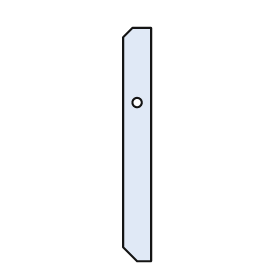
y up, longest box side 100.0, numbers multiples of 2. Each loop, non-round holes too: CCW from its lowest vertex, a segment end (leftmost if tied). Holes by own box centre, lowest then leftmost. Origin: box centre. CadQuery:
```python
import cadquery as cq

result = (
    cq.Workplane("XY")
    .moveTo(0.0, -50.0)
    .lineTo(6.0, -50.0)
    .lineTo(6.0, 50.0)
    .lineTo(-2.0, 50.0)
    .lineTo(-6.0, 46.0)
    .lineTo(-6.0, -44.0)
    .close()
    .moveTo(0.0, 18.0)
    .circle(2.0)
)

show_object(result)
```